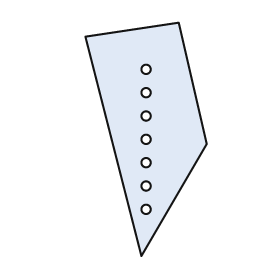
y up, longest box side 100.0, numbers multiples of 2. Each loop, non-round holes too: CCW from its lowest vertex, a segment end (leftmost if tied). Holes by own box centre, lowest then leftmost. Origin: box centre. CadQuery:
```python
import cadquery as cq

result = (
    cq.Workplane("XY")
    .moveTo(-2.0, -50.0)
    .lineTo(26.0, -2.0)
    .lineTo(14.0, 50.0)
    .lineTo(-26.0, 44.0)
    .close()
    .moveTo(0.0, -30.0)
    .circle(2.0)
    .moveTo(0.0, -20.0)
    .circle(2.0)
    .moveTo(0.0, -10.0)
    .circle(2.0)
    .moveTo(0.0, 0.0)
    .circle(2.0)
    .moveTo(0.0, 10.0)
    .circle(2.0)
    .moveTo(0.0, 20.0)
    .circle(2.0)
    .moveTo(0.0, 30.0)
    .circle(2.0)
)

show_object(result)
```